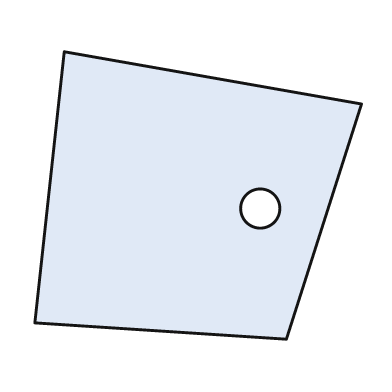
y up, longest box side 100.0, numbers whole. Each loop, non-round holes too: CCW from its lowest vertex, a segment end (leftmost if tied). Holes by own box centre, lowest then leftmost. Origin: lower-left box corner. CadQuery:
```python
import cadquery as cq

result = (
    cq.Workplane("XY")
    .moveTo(77.0, 0.0)
    .lineTo(100.0, 72.0)
    .lineTo(9.0, 88.0)
    .lineTo(0.0, 5.0)
    .close()
    .moveTo(69.0, 40.0)
    .circle(6.0)
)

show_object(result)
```